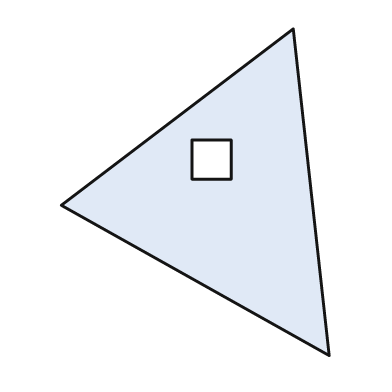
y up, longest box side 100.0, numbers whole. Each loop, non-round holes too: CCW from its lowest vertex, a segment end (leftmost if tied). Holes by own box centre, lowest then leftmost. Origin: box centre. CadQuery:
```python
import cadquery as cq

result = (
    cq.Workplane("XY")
    .moveTo(41.0, -50.0)
    .lineTo(30.0, 50.0)
    .lineTo(-41.0, -4.0)
    .close()
    .moveTo(-1.0, 4.0)
    .lineTo(11.0, 4.0)
    .lineTo(11.0, 16.0)
    .lineTo(-1.0, 16.0)
    .close()
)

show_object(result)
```